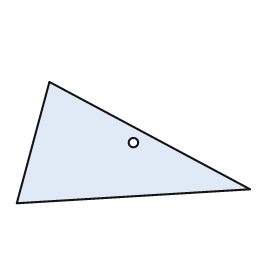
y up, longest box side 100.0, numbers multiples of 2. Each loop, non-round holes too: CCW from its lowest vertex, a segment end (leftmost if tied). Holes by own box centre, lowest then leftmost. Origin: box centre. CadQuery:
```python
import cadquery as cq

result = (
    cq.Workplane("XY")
    .moveTo(-50.0, -26.0)
    .lineTo(50.0, -20.0)
    .lineTo(-36.0, 26.0)
    .close()
    .moveTo(0.0, 0.0)
    .circle(2.0)
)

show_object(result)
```